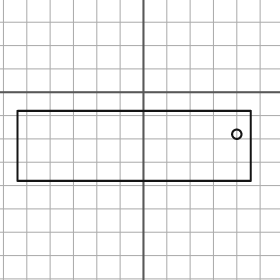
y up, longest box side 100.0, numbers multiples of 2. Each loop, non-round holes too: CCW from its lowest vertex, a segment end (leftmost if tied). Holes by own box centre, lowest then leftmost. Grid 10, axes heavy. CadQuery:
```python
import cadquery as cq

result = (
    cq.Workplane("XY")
    .moveTo(-54.0, -38.0)
    .lineTo(46.0, -38.0)
    .lineTo(46.0, -8.0)
    .lineTo(-54.0, -8.0)
    .close()
    .moveTo(40.0, -18.0)
    .circle(2.0)
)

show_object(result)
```